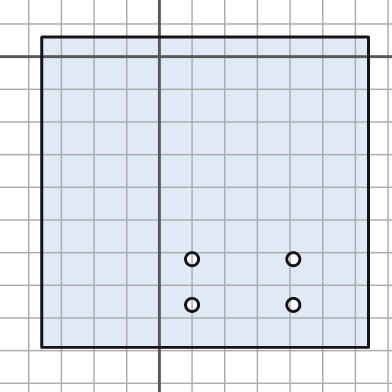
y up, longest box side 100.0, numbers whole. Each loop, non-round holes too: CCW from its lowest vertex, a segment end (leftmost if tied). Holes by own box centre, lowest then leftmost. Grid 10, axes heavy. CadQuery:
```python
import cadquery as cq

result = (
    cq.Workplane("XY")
    .moveTo(-36.0, -89.0)
    .lineTo(64.0, -89.0)
    .lineTo(64.0, 6.0)
    .lineTo(-36.0, 6.0)
    .close()
    .moveTo(10.0, -76.0)
    .circle(2.0)
    .moveTo(41.0, -76.0)
    .circle(2.0)
    .moveTo(10.0, -62.0)
    .circle(2.0)
    .moveTo(41.0, -62.0)
    .circle(2.0)
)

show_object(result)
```